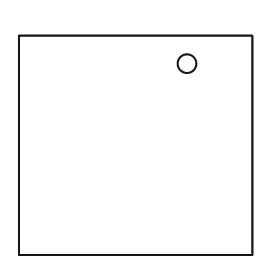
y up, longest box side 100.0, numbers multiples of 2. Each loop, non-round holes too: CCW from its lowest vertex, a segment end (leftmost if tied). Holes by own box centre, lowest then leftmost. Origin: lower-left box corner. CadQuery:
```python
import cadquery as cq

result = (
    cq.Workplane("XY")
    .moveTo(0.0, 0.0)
    .lineTo(100.0, 0.0)
    .lineTo(100.0, 94.0)
    .lineTo(0.0, 94.0)
    .close()
    .moveTo(72.0, 82.0)
    .circle(4.0)
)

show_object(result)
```